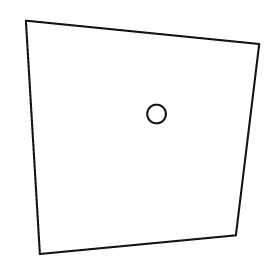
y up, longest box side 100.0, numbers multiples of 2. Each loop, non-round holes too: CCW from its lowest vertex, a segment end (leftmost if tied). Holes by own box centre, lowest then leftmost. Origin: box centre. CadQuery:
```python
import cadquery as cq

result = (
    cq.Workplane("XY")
    .moveTo(-44.0, -50.0)
    .lineTo(40.0, -42.0)
    .lineTo(50.0, 40.0)
    .lineTo(-50.0, 50.0)
    .close()
    .moveTo(6.0, 10.0)
    .circle(4.0)
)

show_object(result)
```